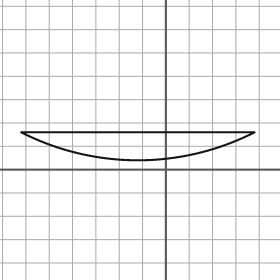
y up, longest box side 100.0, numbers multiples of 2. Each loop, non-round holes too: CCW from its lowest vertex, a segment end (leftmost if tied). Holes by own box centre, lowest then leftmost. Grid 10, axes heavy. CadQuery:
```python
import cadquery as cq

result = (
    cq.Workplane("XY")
    .moveTo(-62.0, 16.0)
    .threePointArc((-12.0, 4.0), (38.0, 16.0))
    .close()
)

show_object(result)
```